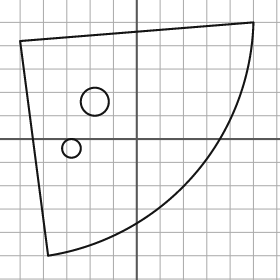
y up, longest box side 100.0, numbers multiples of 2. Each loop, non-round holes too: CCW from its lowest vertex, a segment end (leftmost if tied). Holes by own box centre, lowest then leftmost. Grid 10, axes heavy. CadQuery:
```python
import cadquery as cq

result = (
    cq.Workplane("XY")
    .moveTo(-38.0, -50.0)
    .threePointArc((24.0, -16.0), (50.0, 50.0))
    .lineTo(-50.0, 42.0)
    .close()
    .moveTo(-28.0, -4.0)
    .circle(4.0)
    .moveTo(-18.0, 16.0)
    .circle(6.0)
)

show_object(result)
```